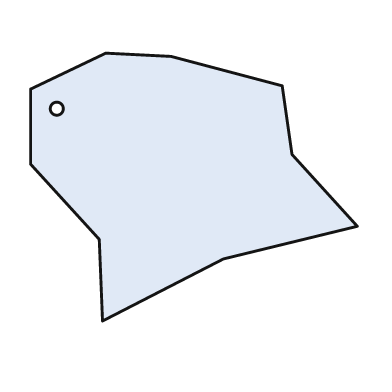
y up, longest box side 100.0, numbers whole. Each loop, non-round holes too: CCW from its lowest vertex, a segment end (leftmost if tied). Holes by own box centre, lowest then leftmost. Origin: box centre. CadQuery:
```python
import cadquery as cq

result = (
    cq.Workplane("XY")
    .moveTo(-28.0, -41.0)
    .lineTo(9.0, -22.0)
    .lineTo(50.0, -12.0)
    .lineTo(30.0, 10.0)
    .lineTo(27.0, 31.0)
    .lineTo(-7.0, 40.0)
    .lineTo(-27.0, 41.0)
    .lineTo(-50.0, 30.0)
    .lineTo(-50.0, 7.0)
    .lineTo(-29.0, -16.0)
    .close()
    .moveTo(-42.0, 24.0)
    .circle(2.0)
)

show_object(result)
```